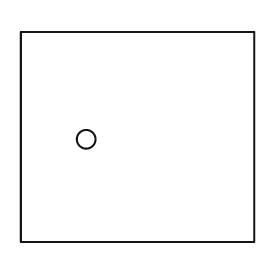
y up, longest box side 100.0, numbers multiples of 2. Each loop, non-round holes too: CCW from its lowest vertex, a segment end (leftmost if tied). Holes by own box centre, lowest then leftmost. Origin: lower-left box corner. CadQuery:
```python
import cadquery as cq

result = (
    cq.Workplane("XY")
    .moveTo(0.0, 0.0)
    .lineTo(100.0, 0.0)
    .lineTo(100.0, 90.0)
    .lineTo(0.0, 90.0)
    .close()
    .moveTo(28.0, 44.0)
    .circle(4.0)
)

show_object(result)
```